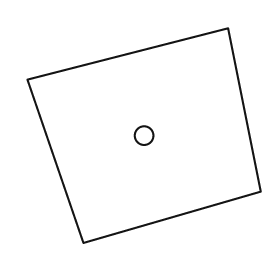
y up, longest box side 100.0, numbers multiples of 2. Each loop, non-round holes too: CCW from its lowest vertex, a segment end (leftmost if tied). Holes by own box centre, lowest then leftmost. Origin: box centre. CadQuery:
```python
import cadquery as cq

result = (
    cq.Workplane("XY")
    .moveTo(-26.0, -46.0)
    .lineTo(50.0, -24.0)
    .lineTo(36.0, 46.0)
    .lineTo(-50.0, 24.0)
    .close()
    .moveTo(0.0, 0.0)
    .circle(4.0)
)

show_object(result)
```